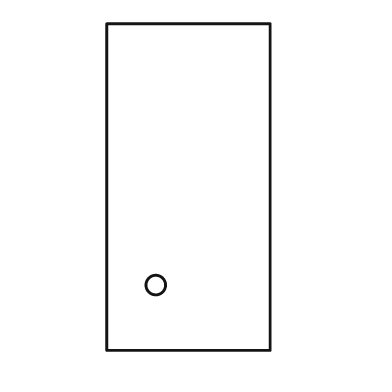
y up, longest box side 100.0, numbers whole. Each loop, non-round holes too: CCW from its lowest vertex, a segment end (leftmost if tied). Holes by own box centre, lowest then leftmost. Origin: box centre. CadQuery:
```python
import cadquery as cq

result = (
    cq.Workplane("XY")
    .moveTo(-25.0, -50.0)
    .lineTo(25.0, -50.0)
    .lineTo(25.0, 50.0)
    .lineTo(-25.0, 50.0)
    .close()
    .moveTo(-10.0, -30.0)
    .circle(3.0)
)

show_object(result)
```